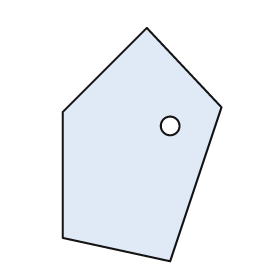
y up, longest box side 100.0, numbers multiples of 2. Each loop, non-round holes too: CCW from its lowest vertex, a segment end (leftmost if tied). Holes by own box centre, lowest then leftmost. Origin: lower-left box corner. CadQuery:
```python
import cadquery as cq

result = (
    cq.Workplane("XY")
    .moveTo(46.0, 0.0)
    .lineTo(68.0, 66.0)
    .lineTo(36.0, 100.0)
    .lineTo(0.0, 64.0)
    .lineTo(0.0, 10.0)
    .close()
    .moveTo(46.0, 58.0)
    .circle(4.0)
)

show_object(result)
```